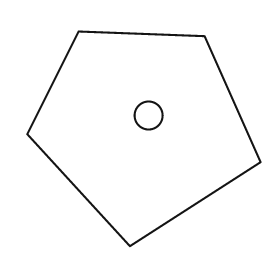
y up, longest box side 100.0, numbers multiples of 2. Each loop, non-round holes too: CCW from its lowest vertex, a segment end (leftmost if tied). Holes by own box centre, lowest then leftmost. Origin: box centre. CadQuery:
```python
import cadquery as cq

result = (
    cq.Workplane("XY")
    .moveTo(-6.0, -46.0)
    .lineTo(50.0, -10.0)
    .lineTo(26.0, 44.0)
    .lineTo(-28.0, 46.0)
    .lineTo(-50.0, 2.0)
    .close()
    .moveTo(2.0, 10.0)
    .circle(6.0)
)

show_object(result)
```